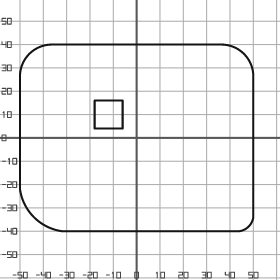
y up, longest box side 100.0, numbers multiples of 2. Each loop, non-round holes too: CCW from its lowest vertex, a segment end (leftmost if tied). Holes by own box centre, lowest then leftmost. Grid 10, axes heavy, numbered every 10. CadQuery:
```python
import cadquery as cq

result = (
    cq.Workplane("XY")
    .moveTo(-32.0, -40.0)
    .lineTo(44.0, -40.0)
    .threePointArc((48.0, -38.0), (50.0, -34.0))
    .lineTo(50.0, 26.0)
    .threePointArc((46.0, 36.0), (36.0, 40.0))
    .lineTo(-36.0, 40.0)
    .threePointArc((-46.0, 36.0), (-50.0, 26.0))
    .lineTo(-50.0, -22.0)
    .threePointArc((-44.0, -34.0), (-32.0, -40.0))
    .close()
    .moveTo(-18.0, 4.0)
    .lineTo(-6.0, 4.0)
    .lineTo(-6.0, 16.0)
    .lineTo(-18.0, 16.0)
    .close()
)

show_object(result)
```